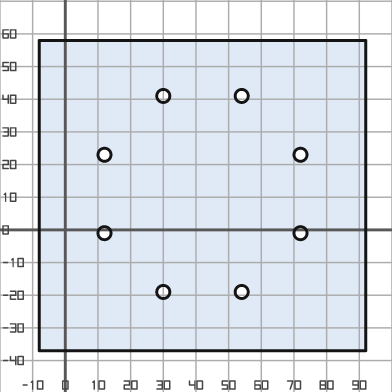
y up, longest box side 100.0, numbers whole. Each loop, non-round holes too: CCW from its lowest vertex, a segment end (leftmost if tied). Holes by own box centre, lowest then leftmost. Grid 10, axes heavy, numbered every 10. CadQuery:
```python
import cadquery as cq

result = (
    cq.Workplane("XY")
    .moveTo(-8.0, -37.0)
    .lineTo(92.0, -37.0)
    .lineTo(92.0, 58.0)
    .lineTo(-8.0, 58.0)
    .close()
    .moveTo(30.0, -19.0)
    .circle(2.0)
    .moveTo(54.0, -19.0)
    .circle(2.0)
    .moveTo(12.0, -1.0)
    .circle(2.0)
    .moveTo(72.0, -1.0)
    .circle(2.0)
    .moveTo(12.0, 23.0)
    .circle(2.0)
    .moveTo(72.0, 23.0)
    .circle(2.0)
    .moveTo(30.0, 41.0)
    .circle(2.0)
    .moveTo(54.0, 41.0)
    .circle(2.0)
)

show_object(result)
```